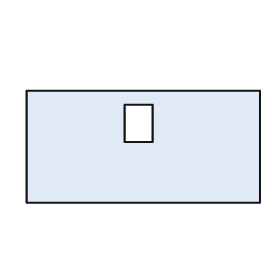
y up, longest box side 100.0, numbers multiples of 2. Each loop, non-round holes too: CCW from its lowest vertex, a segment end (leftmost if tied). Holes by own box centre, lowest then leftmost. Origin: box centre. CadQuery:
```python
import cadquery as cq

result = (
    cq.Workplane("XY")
    .moveTo(-50.0, -24.0)
    .lineTo(50.0, -24.0)
    .lineTo(50.0, 24.0)
    .lineTo(-50.0, 24.0)
    .close()
    .moveTo(-8.0, 2.0)
    .lineTo(4.0, 2.0)
    .lineTo(4.0, 18.0)
    .lineTo(-8.0, 18.0)
    .close()
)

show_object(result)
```